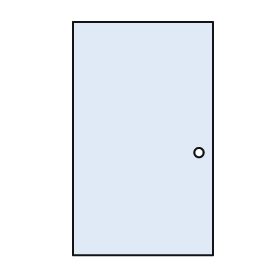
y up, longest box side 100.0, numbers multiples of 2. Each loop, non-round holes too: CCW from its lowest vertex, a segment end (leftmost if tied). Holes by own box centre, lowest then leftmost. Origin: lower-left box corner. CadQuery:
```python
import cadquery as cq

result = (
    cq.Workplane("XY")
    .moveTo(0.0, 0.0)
    .lineTo(60.0, 0.0)
    .lineTo(60.0, 100.0)
    .lineTo(0.0, 100.0)
    .close()
    .moveTo(54.0, 44.0)
    .circle(2.0)
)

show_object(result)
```